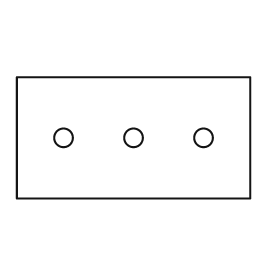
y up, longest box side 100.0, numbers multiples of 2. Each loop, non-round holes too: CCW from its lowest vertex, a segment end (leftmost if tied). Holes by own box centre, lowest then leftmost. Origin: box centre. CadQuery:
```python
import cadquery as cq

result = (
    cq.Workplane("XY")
    .moveTo(-50.0, -26.0)
    .lineTo(50.0, -26.0)
    .lineTo(50.0, 26.0)
    .lineTo(-50.0, 26.0)
    .close()
    .moveTo(-30.0, 0.0)
    .circle(4.0)
    .moveTo(0.0, 0.0)
    .circle(4.0)
    .moveTo(30.0, 0.0)
    .circle(4.0)
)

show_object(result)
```